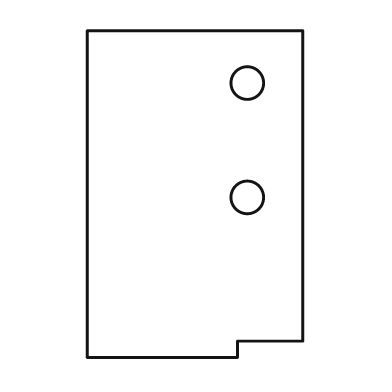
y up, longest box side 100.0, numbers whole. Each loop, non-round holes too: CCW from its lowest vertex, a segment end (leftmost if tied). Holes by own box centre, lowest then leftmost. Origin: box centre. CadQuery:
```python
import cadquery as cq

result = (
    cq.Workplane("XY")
    .moveTo(-33.0, -50.0)
    .lineTo(13.0, -50.0)
    .lineTo(13.0, -45.0)
    .lineTo(33.0, -45.0)
    .lineTo(33.0, 50.0)
    .lineTo(-33.0, 50.0)
    .close()
    .moveTo(16.0, -1.0)
    .circle(5.0)
    .moveTo(16.0, 34.0)
    .circle(5.0)
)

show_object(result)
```